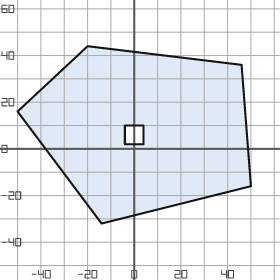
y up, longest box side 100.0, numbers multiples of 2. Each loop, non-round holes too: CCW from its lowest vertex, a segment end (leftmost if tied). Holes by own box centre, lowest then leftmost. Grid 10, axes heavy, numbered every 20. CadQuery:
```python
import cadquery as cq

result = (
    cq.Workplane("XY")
    .moveTo(-14.0, -32.0)
    .lineTo(50.0, -16.0)
    .lineTo(46.0, 36.0)
    .lineTo(-20.0, 44.0)
    .lineTo(-50.0, 16.0)
    .close()
    .moveTo(-4.0, 2.0)
    .lineTo(4.0, 2.0)
    .lineTo(4.0, 10.0)
    .lineTo(-4.0, 10.0)
    .close()
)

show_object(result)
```